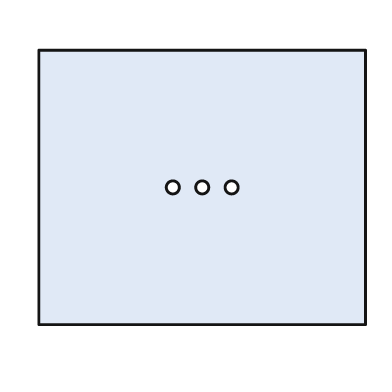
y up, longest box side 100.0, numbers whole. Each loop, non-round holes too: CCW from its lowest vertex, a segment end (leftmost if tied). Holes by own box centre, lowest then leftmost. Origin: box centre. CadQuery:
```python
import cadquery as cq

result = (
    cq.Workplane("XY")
    .moveTo(-50.0, -42.0)
    .lineTo(50.0, -42.0)
    .lineTo(50.0, 42.0)
    .lineTo(-50.0, 42.0)
    .close()
    .moveTo(-9.0, 0.0)
    .circle(2.0)
    .moveTo(0.0, 0.0)
    .circle(2.0)
    .moveTo(9.0, 0.0)
    .circle(2.0)
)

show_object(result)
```